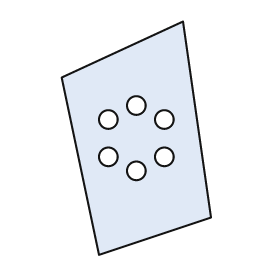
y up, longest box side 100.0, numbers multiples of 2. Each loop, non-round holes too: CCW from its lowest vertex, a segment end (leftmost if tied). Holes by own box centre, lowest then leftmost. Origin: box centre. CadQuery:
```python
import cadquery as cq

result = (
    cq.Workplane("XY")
    .moveTo(-16.0, -50.0)
    .lineTo(32.0, -34.0)
    .lineTo(20.0, 50.0)
    .lineTo(-32.0, 26.0)
    .close()
    .moveTo(0.0, -14.0)
    .circle(4.0)
    .moveTo(-12.0, -8.0)
    .circle(4.0)
    .moveTo(12.0, -8.0)
    .circle(4.0)
    .moveTo(-12.0, 8.0)
    .circle(4.0)
    .moveTo(12.0, 8.0)
    .circle(4.0)
    .moveTo(0.0, 14.0)
    .circle(4.0)
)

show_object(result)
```